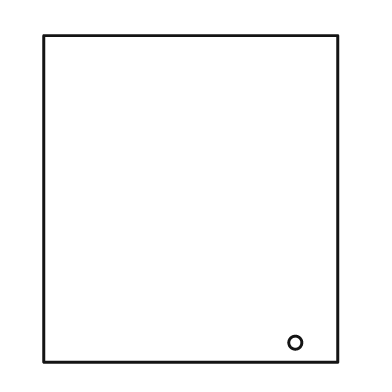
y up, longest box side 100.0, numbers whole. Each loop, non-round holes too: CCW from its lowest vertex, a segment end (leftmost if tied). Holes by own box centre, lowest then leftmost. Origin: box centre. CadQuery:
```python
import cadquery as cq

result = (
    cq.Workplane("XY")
    .moveTo(-45.0, -50.0)
    .lineTo(45.0, -50.0)
    .lineTo(45.0, 50.0)
    .lineTo(-45.0, 50.0)
    .close()
    .moveTo(32.0, -44.0)
    .circle(2.0)
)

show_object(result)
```